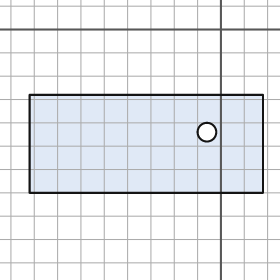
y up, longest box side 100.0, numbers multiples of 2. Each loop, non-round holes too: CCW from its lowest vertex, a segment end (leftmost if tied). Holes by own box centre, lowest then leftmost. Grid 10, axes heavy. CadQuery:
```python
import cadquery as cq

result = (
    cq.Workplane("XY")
    .moveTo(-82.0, -70.0)
    .lineTo(18.0, -70.0)
    .lineTo(18.0, -28.0)
    .lineTo(-82.0, -28.0)
    .close()
    .moveTo(-6.0, -44.0)
    .circle(4.0)
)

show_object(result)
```